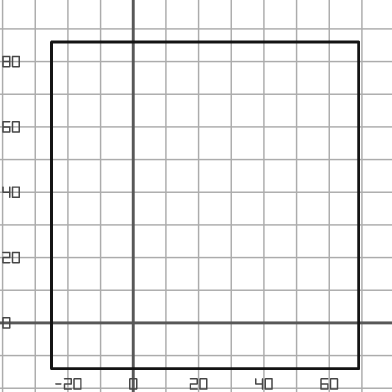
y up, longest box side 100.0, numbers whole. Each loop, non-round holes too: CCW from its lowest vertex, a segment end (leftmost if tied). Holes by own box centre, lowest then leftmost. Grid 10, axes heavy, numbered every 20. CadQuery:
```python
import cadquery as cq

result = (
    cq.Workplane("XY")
    .moveTo(-25.0, -14.0)
    .lineTo(69.0, -14.0)
    .lineTo(69.0, 86.0)
    .lineTo(-25.0, 86.0)
    .close()
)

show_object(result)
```